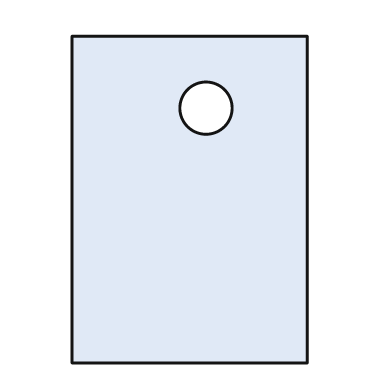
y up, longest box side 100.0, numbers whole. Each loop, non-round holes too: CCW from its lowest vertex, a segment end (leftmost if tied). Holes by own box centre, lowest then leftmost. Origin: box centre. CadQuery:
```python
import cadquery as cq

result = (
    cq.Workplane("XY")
    .moveTo(-36.0, -50.0)
    .lineTo(36.0, -50.0)
    .lineTo(36.0, 50.0)
    .lineTo(-36.0, 50.0)
    .close()
    .moveTo(5.0, 28.0)
    .circle(8.0)
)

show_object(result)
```